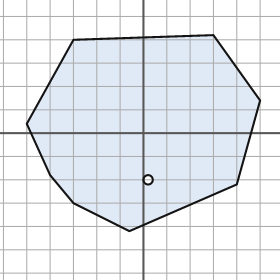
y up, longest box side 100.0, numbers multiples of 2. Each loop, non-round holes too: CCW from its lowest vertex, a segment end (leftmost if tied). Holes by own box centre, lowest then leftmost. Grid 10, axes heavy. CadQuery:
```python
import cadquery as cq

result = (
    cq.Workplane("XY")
    .moveTo(-6.0, -42.0)
    .lineTo(40.0, -22.0)
    .lineTo(50.0, 14.0)
    .lineTo(30.0, 42.0)
    .lineTo(-30.0, 40.0)
    .lineTo(-50.0, 4.0)
    .lineTo(-40.0, -18.0)
    .lineTo(-30.0, -30.0)
    .close()
    .moveTo(2.0, -20.0)
    .circle(2.0)
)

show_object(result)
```